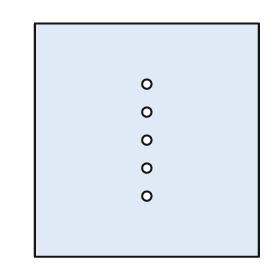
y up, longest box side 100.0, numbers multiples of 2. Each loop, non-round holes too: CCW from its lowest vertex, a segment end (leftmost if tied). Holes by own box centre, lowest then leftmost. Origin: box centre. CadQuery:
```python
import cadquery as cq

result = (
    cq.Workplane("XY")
    .moveTo(-48.0, -50.0)
    .lineTo(48.0, -50.0)
    .lineTo(48.0, 50.0)
    .lineTo(-48.0, 50.0)
    .close()
    .moveTo(0.0, -24.0)
    .circle(2.0)
    .moveTo(0.0, -12.0)
    .circle(2.0)
    .moveTo(0.0, 0.0)
    .circle(2.0)
    .moveTo(0.0, 12.0)
    .circle(2.0)
    .moveTo(0.0, 24.0)
    .circle(2.0)
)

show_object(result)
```